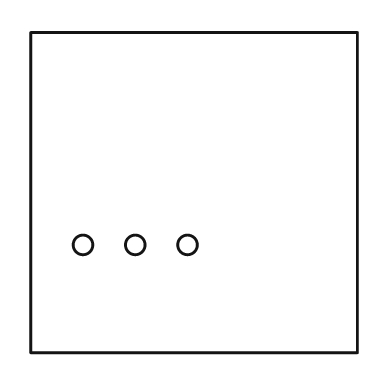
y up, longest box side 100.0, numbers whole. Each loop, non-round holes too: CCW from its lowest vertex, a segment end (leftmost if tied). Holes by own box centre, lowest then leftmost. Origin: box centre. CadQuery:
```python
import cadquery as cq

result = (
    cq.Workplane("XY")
    .moveTo(-50.0, -49.0)
    .lineTo(50.0, -49.0)
    .lineTo(50.0, 49.0)
    .lineTo(-50.0, 49.0)
    .close()
    .moveTo(-34.0, -16.0)
    .circle(3.0)
    .moveTo(-18.0, -16.0)
    .circle(3.0)
    .moveTo(-2.0, -16.0)
    .circle(3.0)
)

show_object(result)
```